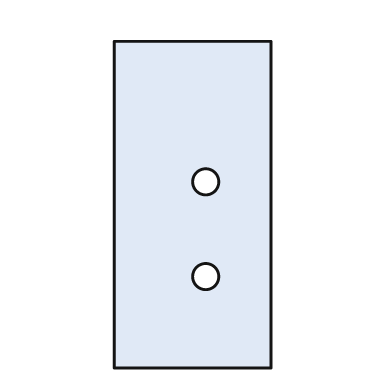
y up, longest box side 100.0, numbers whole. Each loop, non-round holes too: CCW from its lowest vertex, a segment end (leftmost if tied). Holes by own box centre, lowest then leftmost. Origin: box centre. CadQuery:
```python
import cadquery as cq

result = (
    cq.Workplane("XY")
    .moveTo(-24.0, -50.0)
    .lineTo(24.0, -50.0)
    .lineTo(24.0, 50.0)
    .lineTo(-24.0, 50.0)
    .close()
    .moveTo(4.0, -22.0)
    .circle(4.0)
    .moveTo(4.0, 7.0)
    .circle(4.0)
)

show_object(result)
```